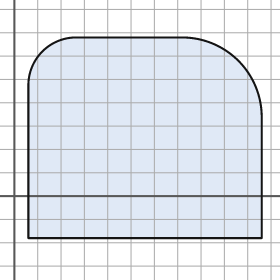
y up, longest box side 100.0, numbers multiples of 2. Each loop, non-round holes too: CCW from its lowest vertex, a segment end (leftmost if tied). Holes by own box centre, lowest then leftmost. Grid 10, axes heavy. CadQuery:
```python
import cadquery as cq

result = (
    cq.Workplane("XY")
    .moveTo(6.0, -18.0)
    .lineTo(106.0, -18.0)
    .lineTo(106.0, 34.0)
    .threePointArc((96.0, 58.0), (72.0, 68.0))
    .lineTo(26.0, 68.0)
    .threePointArc((12.0, 62.0), (6.0, 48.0))
    .close()
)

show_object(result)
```